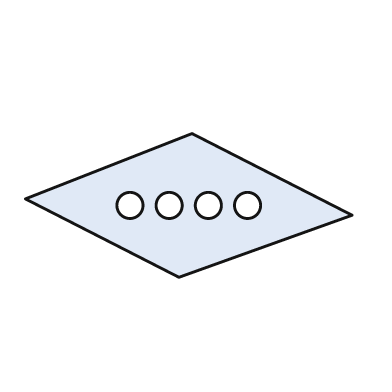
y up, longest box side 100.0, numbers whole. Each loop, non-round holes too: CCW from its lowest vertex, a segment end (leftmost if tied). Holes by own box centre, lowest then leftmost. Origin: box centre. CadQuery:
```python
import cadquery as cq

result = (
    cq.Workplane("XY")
    .moveTo(-3.0, -22.0)
    .lineTo(50.0, -3.0)
    .lineTo(1.0, 22.0)
    .lineTo(-50.0, 2.0)
    .close()
    .moveTo(-18.0, 0.0)
    .circle(4.0)
    .moveTo(-6.0, 0.0)
    .circle(4.0)
    .moveTo(6.0, 0.0)
    .circle(4.0)
    .moveTo(18.0, 0.0)
    .circle(4.0)
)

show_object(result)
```